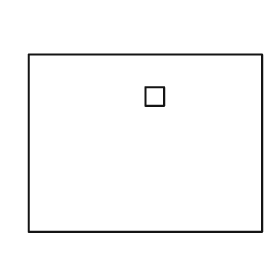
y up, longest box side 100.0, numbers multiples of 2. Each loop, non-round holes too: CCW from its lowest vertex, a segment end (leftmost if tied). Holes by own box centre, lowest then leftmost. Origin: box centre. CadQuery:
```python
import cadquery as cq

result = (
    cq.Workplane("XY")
    .moveTo(-50.0, -38.0)
    .lineTo(50.0, -38.0)
    .lineTo(50.0, 38.0)
    .lineTo(-50.0, 38.0)
    .close()
    .moveTo(0.0, 16.0)
    .lineTo(8.0, 16.0)
    .lineTo(8.0, 24.0)
    .lineTo(0.0, 24.0)
    .close()
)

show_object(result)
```